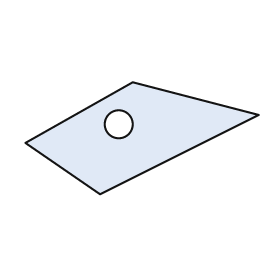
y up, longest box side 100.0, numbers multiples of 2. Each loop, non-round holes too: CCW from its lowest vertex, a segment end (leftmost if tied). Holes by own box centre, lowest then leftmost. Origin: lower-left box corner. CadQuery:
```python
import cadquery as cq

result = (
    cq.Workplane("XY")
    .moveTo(32.0, 0.0)
    .lineTo(100.0, 34.0)
    .lineTo(46.0, 48.0)
    .lineTo(0.0, 22.0)
    .close()
    .moveTo(40.0, 30.0)
    .circle(6.0)
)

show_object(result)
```